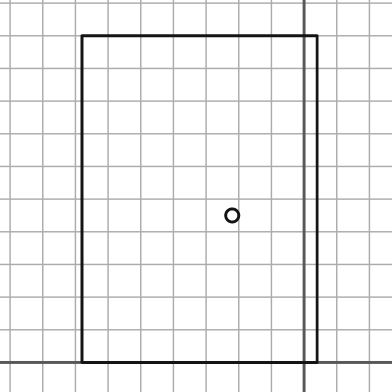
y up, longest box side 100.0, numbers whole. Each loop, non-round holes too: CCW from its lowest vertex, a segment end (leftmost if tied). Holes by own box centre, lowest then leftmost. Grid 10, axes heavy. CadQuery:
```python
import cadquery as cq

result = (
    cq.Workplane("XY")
    .moveTo(-68.0, 0.0)
    .lineTo(4.0, 0.0)
    .lineTo(4.0, 100.0)
    .lineTo(-68.0, 100.0)
    .close()
    .moveTo(-22.0, 45.0)
    .circle(2.0)
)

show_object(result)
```